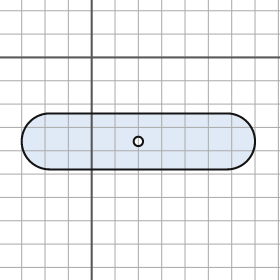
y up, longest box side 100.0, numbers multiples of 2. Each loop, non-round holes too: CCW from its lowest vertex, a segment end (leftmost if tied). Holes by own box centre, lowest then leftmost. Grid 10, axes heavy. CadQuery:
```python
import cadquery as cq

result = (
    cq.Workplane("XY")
    .moveTo(-18.0, -48.0)
    .lineTo(58.0, -48.0)
    .threePointArc((70.0, -36.0), (58.0, -24.0))
    .lineTo(-18.0, -24.0)
    .threePointArc((-30.0, -36.0), (-18.0, -48.0))
    .close()
    .moveTo(20.0, -36.0)
    .circle(2.0)
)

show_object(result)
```